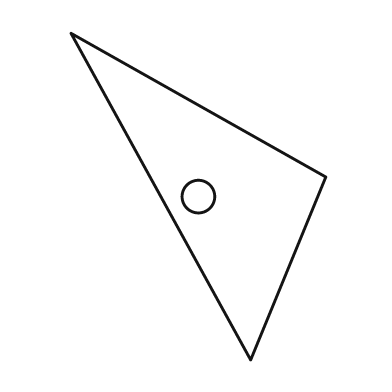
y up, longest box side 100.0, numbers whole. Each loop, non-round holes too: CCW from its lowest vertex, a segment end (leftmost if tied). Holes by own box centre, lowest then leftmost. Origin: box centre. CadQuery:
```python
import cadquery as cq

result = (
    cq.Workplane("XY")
    .moveTo(16.0, -50.0)
    .lineTo(39.0, 6.0)
    .lineTo(-39.0, 50.0)
    .close()
    .moveTo(0.0, 0.0)
    .circle(5.0)
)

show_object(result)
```